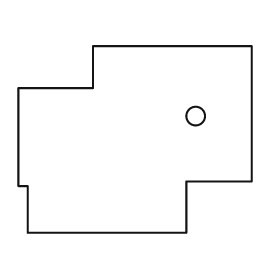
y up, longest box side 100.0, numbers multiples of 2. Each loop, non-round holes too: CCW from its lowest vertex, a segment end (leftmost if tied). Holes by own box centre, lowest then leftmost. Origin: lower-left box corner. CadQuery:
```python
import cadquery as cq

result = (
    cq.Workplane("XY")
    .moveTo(4.0, 0.0)
    .lineTo(72.0, 0.0)
    .lineTo(72.0, 22.0)
    .lineTo(100.0, 22.0)
    .lineTo(100.0, 80.0)
    .lineTo(32.0, 80.0)
    .lineTo(32.0, 62.0)
    .lineTo(0.0, 62.0)
    .lineTo(0.0, 20.0)
    .lineTo(4.0, 20.0)
    .close()
    .moveTo(76.0, 50.0)
    .circle(4.0)
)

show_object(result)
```